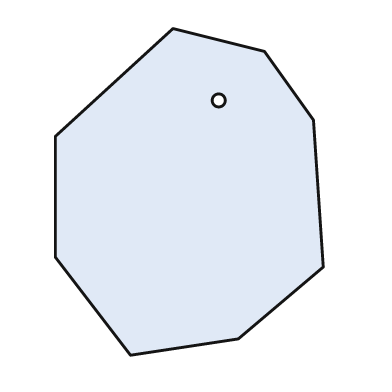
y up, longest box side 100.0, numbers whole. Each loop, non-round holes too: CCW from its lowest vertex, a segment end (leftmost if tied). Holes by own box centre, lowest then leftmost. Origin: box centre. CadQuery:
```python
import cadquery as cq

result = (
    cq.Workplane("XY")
    .moveTo(-18.0, -50.0)
    .lineTo(15.0, -45.0)
    .lineTo(41.0, -23.0)
    .lineTo(38.0, 22.0)
    .lineTo(23.0, 43.0)
    .lineTo(-5.0, 50.0)
    .lineTo(-41.0, 17.0)
    .lineTo(-41.0, -20.0)
    .close()
    .moveTo(9.0, 28.0)
    .circle(2.0)
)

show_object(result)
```